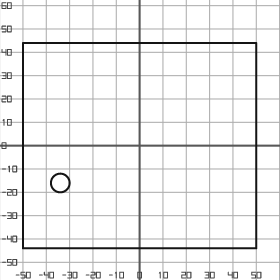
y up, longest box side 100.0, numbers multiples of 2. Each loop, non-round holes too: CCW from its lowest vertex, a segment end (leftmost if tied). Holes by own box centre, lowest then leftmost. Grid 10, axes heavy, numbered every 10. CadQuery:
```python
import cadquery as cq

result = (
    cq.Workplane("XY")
    .moveTo(-50.0, -44.0)
    .lineTo(50.0, -44.0)
    .lineTo(50.0, 44.0)
    .lineTo(-50.0, 44.0)
    .close()
    .moveTo(-34.0, -16.0)
    .circle(4.0)
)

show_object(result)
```